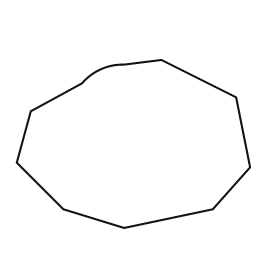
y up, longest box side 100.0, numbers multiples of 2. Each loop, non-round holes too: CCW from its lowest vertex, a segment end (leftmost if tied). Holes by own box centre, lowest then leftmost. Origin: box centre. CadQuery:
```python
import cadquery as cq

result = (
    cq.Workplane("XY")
    .moveTo(-4.0, -36.0)
    .lineTo(34.0, -28.0)
    .lineTo(50.0, -10.0)
    .lineTo(44.0, 20.0)
    .lineTo(12.0, 36.0)
    .lineTo(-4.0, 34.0)
    .threePointArc((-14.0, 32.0), (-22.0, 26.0))
    .lineTo(-44.0, 14.0)
    .lineTo(-50.0, -8.0)
    .lineTo(-30.0, -28.0)
    .close()
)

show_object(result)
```